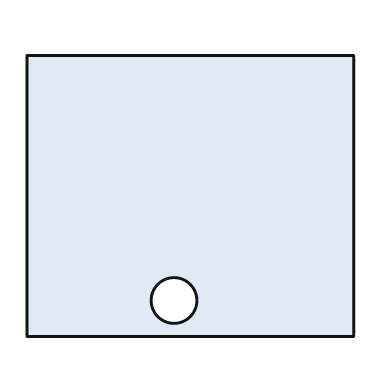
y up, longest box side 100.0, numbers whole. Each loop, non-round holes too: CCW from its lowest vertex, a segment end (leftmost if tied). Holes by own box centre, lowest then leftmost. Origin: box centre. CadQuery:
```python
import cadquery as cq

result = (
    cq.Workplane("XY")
    .moveTo(-50.0, -43.0)
    .lineTo(50.0, -43.0)
    .lineTo(50.0, 43.0)
    .lineTo(-50.0, 43.0)
    .close()
    .moveTo(-5.0, -32.0)
    .circle(7.0)
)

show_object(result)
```